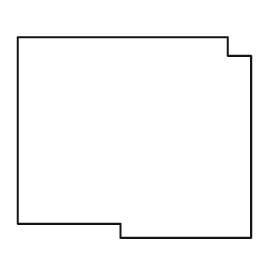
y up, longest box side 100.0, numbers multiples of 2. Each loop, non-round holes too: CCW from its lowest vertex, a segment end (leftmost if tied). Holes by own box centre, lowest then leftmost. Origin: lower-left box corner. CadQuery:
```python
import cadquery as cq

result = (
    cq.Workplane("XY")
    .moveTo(44.0, 0.0)
    .lineTo(100.0, 0.0)
    .lineTo(100.0, 78.0)
    .lineTo(90.0, 78.0)
    .lineTo(90.0, 86.0)
    .lineTo(0.0, 86.0)
    .lineTo(0.0, 6.0)
    .lineTo(44.0, 6.0)
    .close()
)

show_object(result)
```